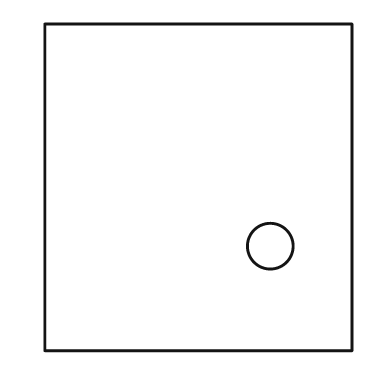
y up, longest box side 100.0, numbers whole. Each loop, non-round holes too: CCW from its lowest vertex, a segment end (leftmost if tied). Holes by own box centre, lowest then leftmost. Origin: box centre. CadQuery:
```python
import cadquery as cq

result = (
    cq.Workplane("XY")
    .moveTo(-47.0, -50.0)
    .lineTo(47.0, -50.0)
    .lineTo(47.0, 50.0)
    .lineTo(-47.0, 50.0)
    .close()
    .moveTo(22.0, -18.0)
    .circle(7.0)
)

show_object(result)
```